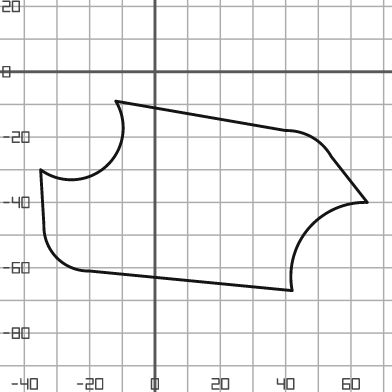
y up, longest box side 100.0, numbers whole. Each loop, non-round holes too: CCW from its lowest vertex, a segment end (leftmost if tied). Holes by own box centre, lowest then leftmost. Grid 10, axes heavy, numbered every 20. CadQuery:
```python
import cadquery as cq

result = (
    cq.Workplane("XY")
    .moveTo(42.0, -67.0)
    .threePointArc((47.0, -48.0), (65.0, -40.0))
    .lineTo(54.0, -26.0)
    .threePointArc((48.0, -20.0), (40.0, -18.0))
    .lineTo(-12.0, -9.0)
    .threePointArc((-15.0, -29.0), (-35.0, -30.0))
    .lineTo(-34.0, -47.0)
    .threePointArc((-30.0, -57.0), (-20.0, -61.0))
    .close()
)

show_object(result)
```